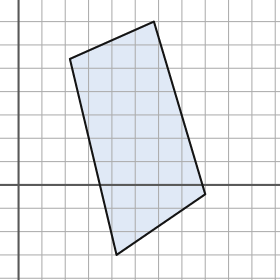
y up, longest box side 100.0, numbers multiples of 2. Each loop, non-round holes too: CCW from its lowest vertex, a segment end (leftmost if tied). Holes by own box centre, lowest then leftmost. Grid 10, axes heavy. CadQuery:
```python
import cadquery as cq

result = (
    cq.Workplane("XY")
    .moveTo(42.0, -30.0)
    .lineTo(80.0, -4.0)
    .lineTo(58.0, 70.0)
    .lineTo(22.0, 54.0)
    .close()
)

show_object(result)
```